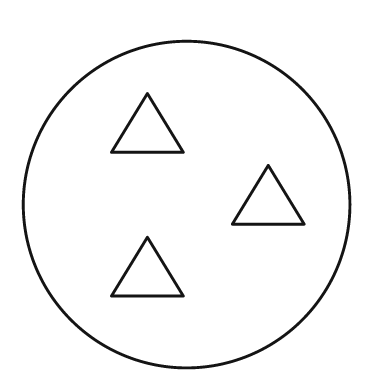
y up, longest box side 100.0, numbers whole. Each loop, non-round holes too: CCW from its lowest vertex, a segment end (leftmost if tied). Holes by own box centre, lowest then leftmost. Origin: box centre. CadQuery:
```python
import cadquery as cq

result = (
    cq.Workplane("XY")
    .moveTo(0.0, 0.0)
    .circle(50.0)
    .moveTo(-23.0, -28.0)
    .lineTo(-1.0, -28.0)
    .lineTo(-12.0, -10.0)
    .close()
    .moveTo(14.0, -6.0)
    .lineTo(36.0, -6.0)
    .lineTo(25.0, 12.0)
    .close()
    .moveTo(-23.0, 16.0)
    .lineTo(-1.0, 16.0)
    .lineTo(-12.0, 34.0)
    .close()
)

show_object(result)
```